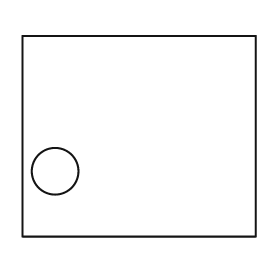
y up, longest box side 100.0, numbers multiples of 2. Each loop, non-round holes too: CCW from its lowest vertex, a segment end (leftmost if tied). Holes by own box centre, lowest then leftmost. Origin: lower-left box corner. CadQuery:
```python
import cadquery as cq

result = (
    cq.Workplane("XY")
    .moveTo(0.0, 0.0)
    .lineTo(100.0, 0.0)
    .lineTo(100.0, 86.0)
    .lineTo(0.0, 86.0)
    .close()
    .moveTo(14.0, 28.0)
    .circle(10.0)
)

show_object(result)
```